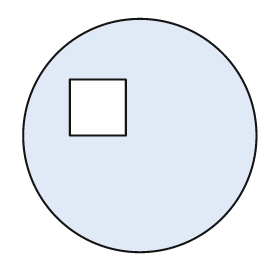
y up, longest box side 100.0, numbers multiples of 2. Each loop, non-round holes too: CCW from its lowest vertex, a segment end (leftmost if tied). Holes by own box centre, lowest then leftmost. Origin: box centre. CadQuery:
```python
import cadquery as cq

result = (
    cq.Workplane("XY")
    .moveTo(0.0, 0.0)
    .circle(50.0)
    .moveTo(-30.0, 0.0)
    .lineTo(-6.0, 0.0)
    .lineTo(-6.0, 24.0)
    .lineTo(-30.0, 24.0)
    .close()
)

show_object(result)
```